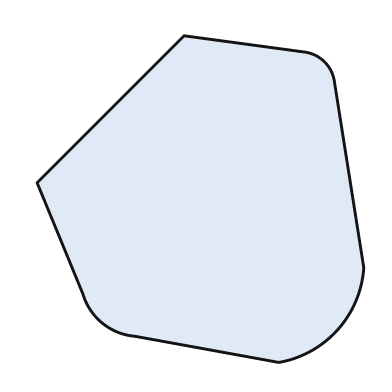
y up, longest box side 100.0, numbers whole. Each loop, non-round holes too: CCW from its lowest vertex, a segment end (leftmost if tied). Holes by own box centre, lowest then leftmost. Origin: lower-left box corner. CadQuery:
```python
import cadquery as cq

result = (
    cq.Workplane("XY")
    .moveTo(74.0, 0.0)
    .threePointArc((92.0, 10.0), (100.0, 29.0))
    .lineTo(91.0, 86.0)
    .threePointArc((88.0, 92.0), (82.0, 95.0))
    .lineTo(45.0, 100.0)
    .lineTo(0.0, 55.0)
    .lineTo(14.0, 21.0)
    .threePointArc((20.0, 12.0), (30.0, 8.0))
    .close()
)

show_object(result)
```